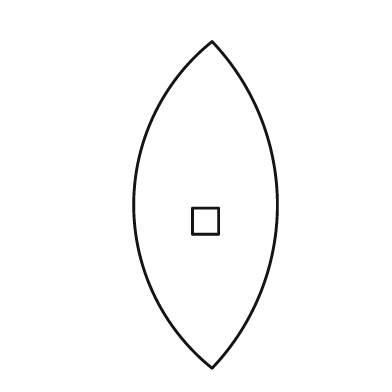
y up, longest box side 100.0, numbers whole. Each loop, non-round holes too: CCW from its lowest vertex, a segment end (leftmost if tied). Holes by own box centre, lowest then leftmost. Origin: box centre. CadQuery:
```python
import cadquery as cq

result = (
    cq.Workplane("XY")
    .moveTo(2.0, -50.0)
    .threePointArc((22.0, 0.0), (2.0, 50.0))
    .threePointArc((-22.0, 0.0), (2.0, -50.0))
    .close()
    .moveTo(-4.0, -9.0)
    .lineTo(4.0, -9.0)
    .lineTo(4.0, -1.0)
    .lineTo(-4.0, -1.0)
    .close()
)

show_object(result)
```